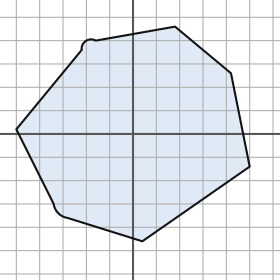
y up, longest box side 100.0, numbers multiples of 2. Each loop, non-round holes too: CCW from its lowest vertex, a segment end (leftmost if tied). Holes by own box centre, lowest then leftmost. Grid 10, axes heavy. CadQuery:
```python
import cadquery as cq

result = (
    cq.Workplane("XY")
    .moveTo(4.0, -46.0)
    .lineTo(50.0, -14.0)
    .lineTo(42.0, 26.0)
    .lineTo(18.0, 46.0)
    .lineTo(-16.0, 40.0)
    .threePointArc((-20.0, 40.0), (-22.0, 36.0))
    .lineTo(-50.0, 2.0)
    .lineTo(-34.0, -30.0)
    .threePointArc((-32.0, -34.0), (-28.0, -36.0))
    .close()
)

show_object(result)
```